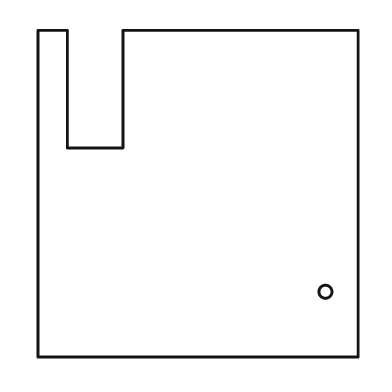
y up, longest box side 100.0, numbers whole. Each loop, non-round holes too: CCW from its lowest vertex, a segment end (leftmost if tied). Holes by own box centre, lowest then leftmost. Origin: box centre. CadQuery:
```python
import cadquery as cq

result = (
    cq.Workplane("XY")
    .moveTo(-49.0, -50.0)
    .lineTo(49.0, -50.0)
    .lineTo(49.0, 50.0)
    .lineTo(-23.0, 50.0)
    .lineTo(-23.0, 14.0)
    .lineTo(-40.0, 14.0)
    .lineTo(-40.0, 50.0)
    .lineTo(-49.0, 50.0)
    .close()
    .moveTo(39.0, -30.0)
    .circle(2.0)
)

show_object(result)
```